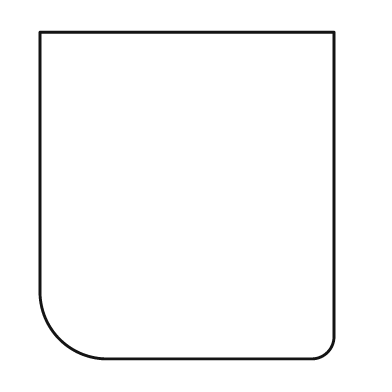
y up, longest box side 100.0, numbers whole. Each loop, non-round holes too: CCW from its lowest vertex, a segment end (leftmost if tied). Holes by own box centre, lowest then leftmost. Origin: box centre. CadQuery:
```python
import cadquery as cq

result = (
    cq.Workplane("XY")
    .moveTo(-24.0, -50.0)
    .lineTo(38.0, -50.0)
    .threePointArc((43.0, -48.0), (45.0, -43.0))
    .lineTo(45.0, 50.0)
    .lineTo(-45.0, 50.0)
    .lineTo(-45.0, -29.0)
    .threePointArc((-39.0, -44.0), (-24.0, -50.0))
    .close()
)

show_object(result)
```